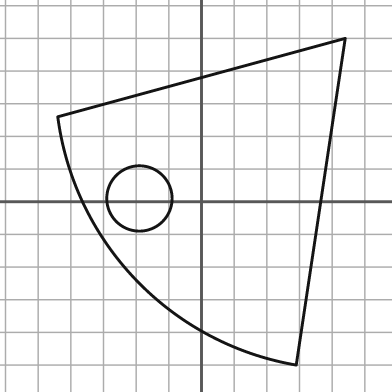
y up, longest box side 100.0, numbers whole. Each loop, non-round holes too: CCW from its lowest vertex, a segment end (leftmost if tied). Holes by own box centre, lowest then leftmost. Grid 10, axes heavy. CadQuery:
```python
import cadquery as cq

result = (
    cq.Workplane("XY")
    .moveTo(29.0, -50.0)
    .lineTo(44.0, 50.0)
    .lineTo(-44.0, 26.0)
    .threePointArc((-20.0, -24.0), (29.0, -50.0))
    .close()
    .moveTo(-19.0, 1.0)
    .circle(10.0)
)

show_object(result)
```